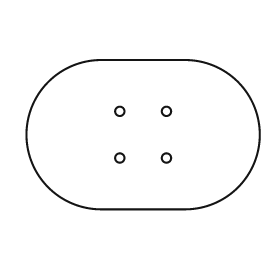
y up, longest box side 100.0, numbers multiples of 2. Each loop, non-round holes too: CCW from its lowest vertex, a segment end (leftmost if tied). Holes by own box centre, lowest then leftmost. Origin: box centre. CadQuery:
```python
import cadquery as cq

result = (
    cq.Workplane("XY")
    .moveTo(-18.0, -32.0)
    .lineTo(18.0, -32.0)
    .threePointArc((50.0, 0.0), (18.0, 32.0))
    .lineTo(-18.0, 32.0)
    .threePointArc((-50.0, 0.0), (-18.0, -32.0))
    .close()
    .moveTo(-10.0, -10.0)
    .circle(2.0)
    .moveTo(10.0, -10.0)
    .circle(2.0)
    .moveTo(-10.0, 10.0)
    .circle(2.0)
    .moveTo(10.0, 10.0)
    .circle(2.0)
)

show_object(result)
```